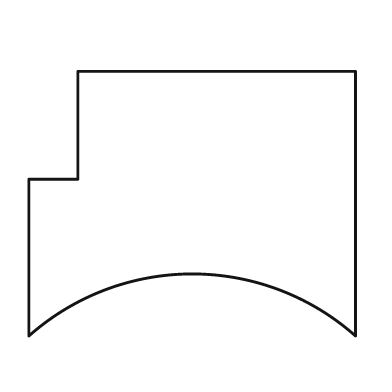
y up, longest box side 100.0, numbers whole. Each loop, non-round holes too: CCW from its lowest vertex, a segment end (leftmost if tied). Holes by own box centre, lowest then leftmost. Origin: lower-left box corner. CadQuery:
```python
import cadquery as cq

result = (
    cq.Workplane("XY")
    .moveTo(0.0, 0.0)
    .threePointArc((50.0, 19.0), (100.0, 0.0))
    .lineTo(100.0, 81.0)
    .lineTo(15.0, 81.0)
    .lineTo(15.0, 48.0)
    .lineTo(0.0, 48.0)
    .close()
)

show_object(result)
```